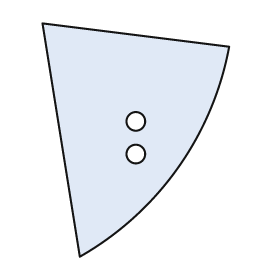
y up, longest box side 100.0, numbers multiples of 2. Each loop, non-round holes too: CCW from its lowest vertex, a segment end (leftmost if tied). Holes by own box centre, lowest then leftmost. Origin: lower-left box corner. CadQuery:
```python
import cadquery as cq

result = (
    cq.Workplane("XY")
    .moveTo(16.0, 0.0)
    .threePointArc((58.0, 38.0), (80.0, 90.0))
    .lineTo(0.0, 100.0)
    .close()
    .moveTo(40.0, 44.0)
    .circle(4.0)
    .moveTo(40.0, 58.0)
    .circle(4.0)
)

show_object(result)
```